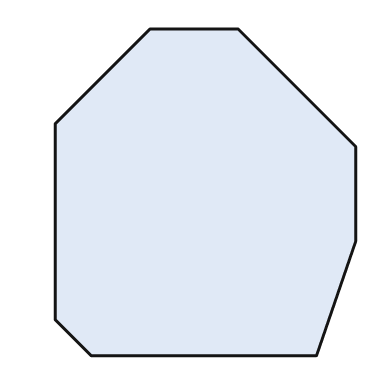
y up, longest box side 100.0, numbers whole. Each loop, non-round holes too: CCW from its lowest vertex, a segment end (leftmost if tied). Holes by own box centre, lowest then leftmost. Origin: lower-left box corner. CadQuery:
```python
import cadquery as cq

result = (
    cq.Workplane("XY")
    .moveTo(11.0, 0.0)
    .lineTo(80.0, 0.0)
    .lineTo(92.0, 35.0)
    .lineTo(92.0, 64.0)
    .lineTo(56.0, 100.0)
    .lineTo(29.0, 100.0)
    .lineTo(0.0, 71.0)
    .lineTo(0.0, 11.0)
    .close()
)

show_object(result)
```